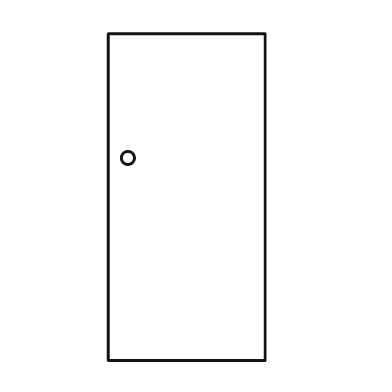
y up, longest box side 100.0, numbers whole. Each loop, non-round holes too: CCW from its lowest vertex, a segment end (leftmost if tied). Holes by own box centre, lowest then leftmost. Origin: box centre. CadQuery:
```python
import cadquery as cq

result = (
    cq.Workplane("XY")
    .moveTo(-24.0, -50.0)
    .lineTo(24.0, -50.0)
    .lineTo(24.0, 50.0)
    .lineTo(-24.0, 50.0)
    .close()
    .moveTo(-18.0, 12.0)
    .circle(2.0)
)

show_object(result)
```